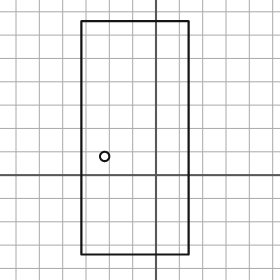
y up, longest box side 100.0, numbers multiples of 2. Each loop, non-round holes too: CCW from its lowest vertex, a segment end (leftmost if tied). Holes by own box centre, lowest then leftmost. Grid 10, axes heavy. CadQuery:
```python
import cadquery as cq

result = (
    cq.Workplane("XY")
    .moveTo(-32.0, -34.0)
    .lineTo(14.0, -34.0)
    .lineTo(14.0, 66.0)
    .lineTo(-32.0, 66.0)
    .close()
    .moveTo(-22.0, 8.0)
    .circle(2.0)
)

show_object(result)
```